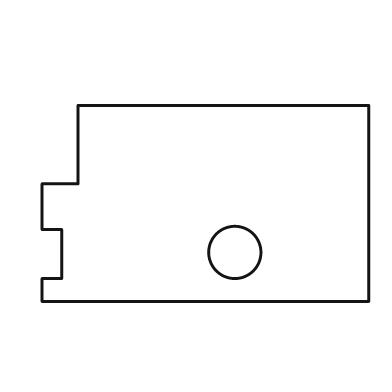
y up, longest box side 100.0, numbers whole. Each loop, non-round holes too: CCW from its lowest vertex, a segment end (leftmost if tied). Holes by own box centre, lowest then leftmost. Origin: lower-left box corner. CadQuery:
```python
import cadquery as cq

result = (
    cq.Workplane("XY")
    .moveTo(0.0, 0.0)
    .lineTo(100.0, 0.0)
    .lineTo(100.0, 60.0)
    .lineTo(11.0, 60.0)
    .lineTo(11.0, 36.0)
    .lineTo(0.0, 36.0)
    .lineTo(0.0, 22.0)
    .lineTo(6.0, 22.0)
    .lineTo(6.0, 7.0)
    .lineTo(0.0, 7.0)
    .close()
    .moveTo(59.0, 15.0)
    .circle(8.0)
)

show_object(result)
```